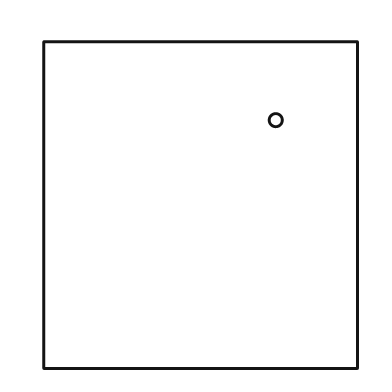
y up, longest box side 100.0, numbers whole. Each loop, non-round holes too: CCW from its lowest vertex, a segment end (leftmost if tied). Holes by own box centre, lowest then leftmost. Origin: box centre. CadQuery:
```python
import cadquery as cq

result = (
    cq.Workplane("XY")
    .moveTo(-48.0, -50.0)
    .lineTo(48.0, -50.0)
    .lineTo(48.0, 50.0)
    .lineTo(-48.0, 50.0)
    .close()
    .moveTo(23.0, 26.0)
    .circle(2.0)
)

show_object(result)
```